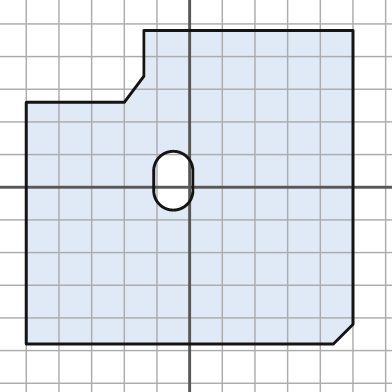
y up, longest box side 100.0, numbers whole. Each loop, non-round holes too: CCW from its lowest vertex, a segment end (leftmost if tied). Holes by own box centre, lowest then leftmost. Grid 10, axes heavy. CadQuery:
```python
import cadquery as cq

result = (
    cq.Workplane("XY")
    .moveTo(-50.0, -48.0)
    .lineTo(44.0, -48.0)
    .lineTo(50.0, -42.0)
    .lineTo(50.0, 48.0)
    .lineTo(-14.0, 48.0)
    .lineTo(-14.0, 34.0)
    .lineTo(-20.0, 26.0)
    .lineTo(-50.0, 26.0)
    .close()
    .moveTo(-11.0, -1.0)
    .threePointArc((-5.0, -7.0), (1.0, -1.0))
    .lineTo(1.0, 5.0)
    .threePointArc((-5.0, 11.0), (-11.0, 5.0))
    .close()
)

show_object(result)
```